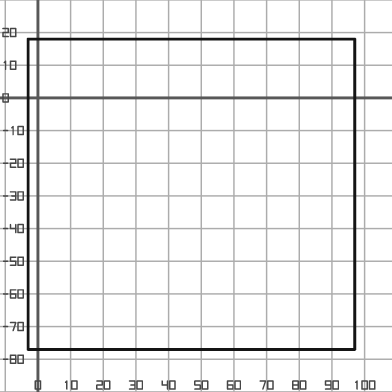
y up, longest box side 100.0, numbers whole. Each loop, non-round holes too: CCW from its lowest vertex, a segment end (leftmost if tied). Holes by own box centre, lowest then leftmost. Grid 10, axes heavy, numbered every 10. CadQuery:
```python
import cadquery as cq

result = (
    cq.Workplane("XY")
    .moveTo(-3.0, -77.0)
    .lineTo(97.0, -77.0)
    .lineTo(97.0, 18.0)
    .lineTo(-3.0, 18.0)
    .close()
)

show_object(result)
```